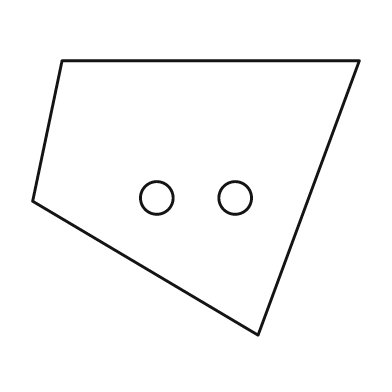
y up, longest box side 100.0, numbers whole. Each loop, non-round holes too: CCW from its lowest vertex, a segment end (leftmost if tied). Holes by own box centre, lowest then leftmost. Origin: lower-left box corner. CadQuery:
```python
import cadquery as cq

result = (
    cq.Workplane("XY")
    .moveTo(69.0, 0.0)
    .lineTo(100.0, 84.0)
    .lineTo(9.0, 84.0)
    .lineTo(0.0, 41.0)
    .close()
    .moveTo(38.0, 42.0)
    .circle(5.0)
    .moveTo(62.0, 42.0)
    .circle(5.0)
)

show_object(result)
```